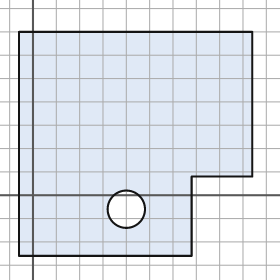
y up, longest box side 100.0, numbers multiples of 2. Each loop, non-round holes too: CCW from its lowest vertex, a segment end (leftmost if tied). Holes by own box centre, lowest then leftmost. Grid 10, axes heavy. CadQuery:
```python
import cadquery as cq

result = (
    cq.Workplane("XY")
    .moveTo(-6.0, -26.0)
    .lineTo(68.0, -26.0)
    .lineTo(68.0, 8.0)
    .lineTo(94.0, 8.0)
    .lineTo(94.0, 70.0)
    .lineTo(-6.0, 70.0)
    .close()
    .moveTo(40.0, -6.0)
    .circle(8.0)
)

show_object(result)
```